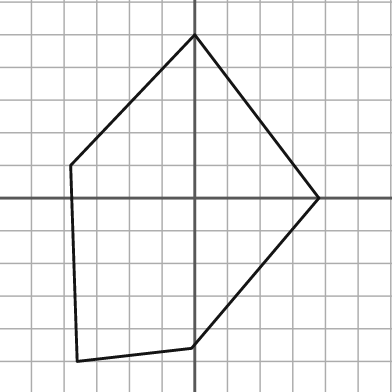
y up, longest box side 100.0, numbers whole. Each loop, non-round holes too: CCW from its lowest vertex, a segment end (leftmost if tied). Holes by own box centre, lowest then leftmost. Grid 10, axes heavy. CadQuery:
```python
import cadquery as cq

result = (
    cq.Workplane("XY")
    .moveTo(-36.0, -50.0)
    .lineTo(-1.0, -46.0)
    .lineTo(38.0, 0.0)
    .lineTo(0.0, 50.0)
    .lineTo(-38.0, 10.0)
    .close()
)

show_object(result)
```